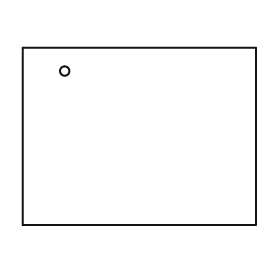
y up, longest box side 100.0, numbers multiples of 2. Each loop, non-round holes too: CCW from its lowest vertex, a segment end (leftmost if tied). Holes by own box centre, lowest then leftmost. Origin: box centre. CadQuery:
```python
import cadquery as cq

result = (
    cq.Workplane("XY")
    .moveTo(-50.0, -38.0)
    .lineTo(50.0, -38.0)
    .lineTo(50.0, 38.0)
    .lineTo(-50.0, 38.0)
    .close()
    .moveTo(-32.0, 28.0)
    .circle(2.0)
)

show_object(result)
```